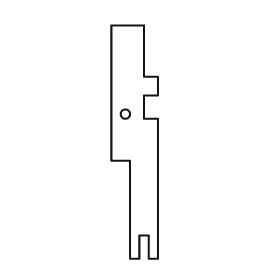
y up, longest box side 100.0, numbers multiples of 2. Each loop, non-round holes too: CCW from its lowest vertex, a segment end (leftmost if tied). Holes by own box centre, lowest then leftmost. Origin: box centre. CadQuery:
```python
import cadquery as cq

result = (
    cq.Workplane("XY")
    .moveTo(-2.0, -50.0)
    .lineTo(2.0, -50.0)
    .lineTo(2.0, -40.0)
    .lineTo(6.0, -40.0)
    .lineTo(6.0, -50.0)
    .lineTo(10.0, -50.0)
    .lineTo(10.0, 10.0)
    .lineTo(4.0, 10.0)
    .lineTo(4.0, 20.0)
    .lineTo(10.0, 20.0)
    .lineTo(10.0, 28.0)
    .lineTo(4.0, 28.0)
    .lineTo(4.0, 50.0)
    .lineTo(-10.0, 50.0)
    .lineTo(-10.0, -8.0)
    .lineTo(-2.0, -8.0)
    .close()
    .moveTo(-4.0, 12.0)
    .circle(2.0)
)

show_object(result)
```